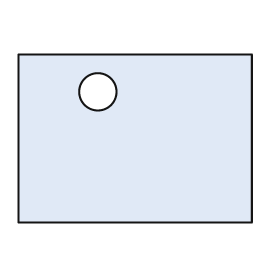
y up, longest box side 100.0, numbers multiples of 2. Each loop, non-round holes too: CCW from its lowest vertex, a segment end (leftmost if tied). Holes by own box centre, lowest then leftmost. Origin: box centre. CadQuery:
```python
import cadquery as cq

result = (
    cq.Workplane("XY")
    .moveTo(-50.0, -36.0)
    .lineTo(50.0, -36.0)
    .lineTo(50.0, 36.0)
    .lineTo(-50.0, 36.0)
    .close()
    .moveTo(-16.0, 20.0)
    .circle(8.0)
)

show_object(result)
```